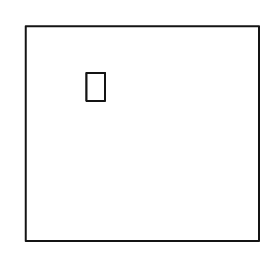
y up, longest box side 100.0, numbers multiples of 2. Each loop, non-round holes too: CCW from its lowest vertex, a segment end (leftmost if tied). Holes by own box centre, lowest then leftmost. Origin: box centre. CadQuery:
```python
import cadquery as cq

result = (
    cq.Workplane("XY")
    .moveTo(-50.0, -46.0)
    .lineTo(50.0, -46.0)
    .lineTo(50.0, 46.0)
    .lineTo(-50.0, 46.0)
    .close()
    .moveTo(-24.0, 14.0)
    .lineTo(-16.0, 14.0)
    .lineTo(-16.0, 26.0)
    .lineTo(-24.0, 26.0)
    .close()
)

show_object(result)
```